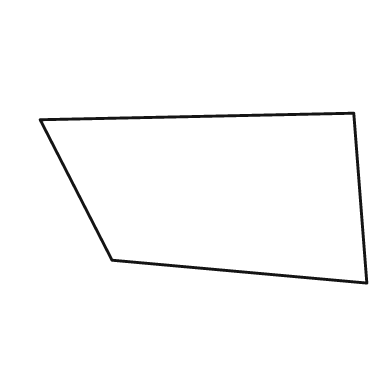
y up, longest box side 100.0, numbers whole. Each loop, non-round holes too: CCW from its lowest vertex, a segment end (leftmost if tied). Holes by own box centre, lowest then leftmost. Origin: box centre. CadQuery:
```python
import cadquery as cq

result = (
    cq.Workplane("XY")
    .moveTo(50.0, -26.0)
    .lineTo(46.0, 26.0)
    .lineTo(-50.0, 24.0)
    .lineTo(-28.0, -19.0)
    .close()
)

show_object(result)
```